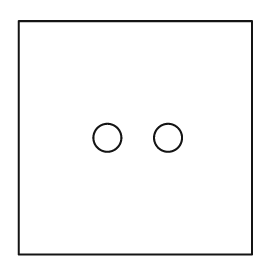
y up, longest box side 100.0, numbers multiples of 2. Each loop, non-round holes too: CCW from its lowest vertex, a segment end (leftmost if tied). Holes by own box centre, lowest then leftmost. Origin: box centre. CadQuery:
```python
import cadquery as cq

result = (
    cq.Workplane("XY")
    .moveTo(-50.0, -50.0)
    .lineTo(50.0, -50.0)
    .lineTo(50.0, 50.0)
    .lineTo(-50.0, 50.0)
    .close()
    .moveTo(-12.0, 0.0)
    .circle(6.0)
    .moveTo(14.0, 0.0)
    .circle(6.0)
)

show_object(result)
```